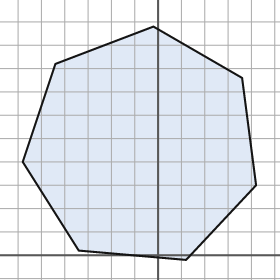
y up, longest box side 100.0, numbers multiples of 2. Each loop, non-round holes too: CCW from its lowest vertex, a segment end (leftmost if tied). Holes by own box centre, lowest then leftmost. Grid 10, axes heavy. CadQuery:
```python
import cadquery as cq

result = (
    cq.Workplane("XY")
    .moveTo(12.0, -2.0)
    .lineTo(42.0, 30.0)
    .lineTo(36.0, 76.0)
    .lineTo(-2.0, 98.0)
    .lineTo(-44.0, 82.0)
    .lineTo(-58.0, 40.0)
    .lineTo(-34.0, 2.0)
    .close()
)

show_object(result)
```